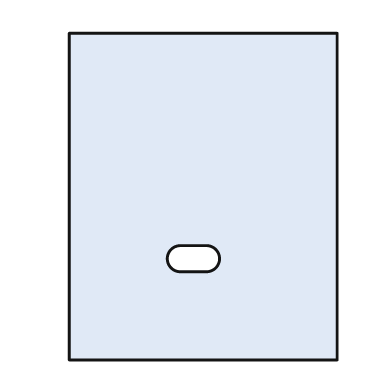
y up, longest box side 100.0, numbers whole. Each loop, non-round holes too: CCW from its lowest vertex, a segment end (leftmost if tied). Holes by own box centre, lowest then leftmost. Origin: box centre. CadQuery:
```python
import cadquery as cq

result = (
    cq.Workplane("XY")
    .moveTo(-41.0, -50.0)
    .lineTo(41.0, -50.0)
    .lineTo(41.0, 50.0)
    .lineTo(-41.0, 50.0)
    .close()
    .moveTo(-7.0, -23.0)
    .lineTo(1.0, -23.0)
    .threePointArc((5.0, -19.0), (1.0, -15.0))
    .lineTo(-7.0, -15.0)
    .threePointArc((-11.0, -19.0), (-7.0, -23.0))
    .close()
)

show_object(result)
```